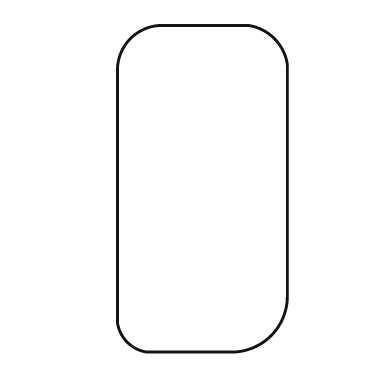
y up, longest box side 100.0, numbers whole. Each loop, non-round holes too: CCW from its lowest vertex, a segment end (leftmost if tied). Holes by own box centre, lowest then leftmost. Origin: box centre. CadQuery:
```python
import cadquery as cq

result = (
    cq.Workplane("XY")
    .moveTo(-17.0, -50.0)
    .lineTo(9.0, -50.0)
    .threePointArc((21.0, -45.0), (26.0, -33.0))
    .lineTo(26.0, 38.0)
    .threePointArc((22.0, 46.0), (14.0, 50.0))
    .lineTo(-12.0, 50.0)
    .threePointArc((-22.0, 46.0), (-26.0, 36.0))
    .lineTo(-26.0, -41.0)
    .threePointArc((-23.0, -47.0), (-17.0, -50.0))
    .close()
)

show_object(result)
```